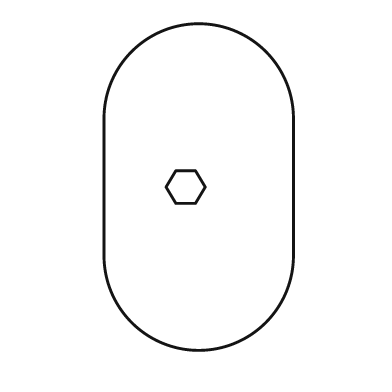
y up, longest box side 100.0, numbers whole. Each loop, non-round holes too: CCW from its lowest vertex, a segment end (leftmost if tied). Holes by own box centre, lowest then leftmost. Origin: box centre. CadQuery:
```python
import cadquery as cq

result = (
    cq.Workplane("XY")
    .moveTo(-29.0, -21.0)
    .threePointArc((0.0, -50.0), (29.0, -21.0))
    .lineTo(29.0, 21.0)
    .threePointArc((0.0, 50.0), (-29.0, 21.0))
    .close()
    .moveTo(-7.0, -5.0)
    .lineTo(-1.0, -5.0)
    .lineTo(2.0, 0.0)
    .lineTo(-1.0, 5.0)
    .lineTo(-7.0, 5.0)
    .lineTo(-10.0, 0.0)
    .close()
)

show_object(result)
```